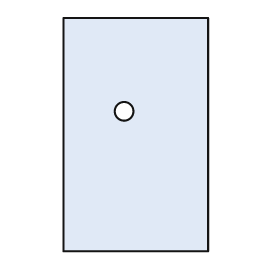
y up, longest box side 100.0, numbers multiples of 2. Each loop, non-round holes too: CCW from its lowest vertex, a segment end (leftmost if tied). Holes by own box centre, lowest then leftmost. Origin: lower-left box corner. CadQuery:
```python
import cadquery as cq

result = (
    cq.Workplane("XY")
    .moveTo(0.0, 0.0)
    .lineTo(62.0, 0.0)
    .lineTo(62.0, 100.0)
    .lineTo(0.0, 100.0)
    .close()
    .moveTo(26.0, 60.0)
    .circle(4.0)
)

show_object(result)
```